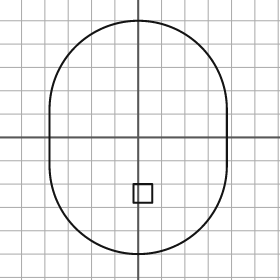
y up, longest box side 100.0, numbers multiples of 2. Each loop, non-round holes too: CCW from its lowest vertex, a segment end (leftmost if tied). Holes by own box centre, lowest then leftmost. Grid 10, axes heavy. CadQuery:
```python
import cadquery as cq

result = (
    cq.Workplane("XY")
    .moveTo(-38.0, -12.0)
    .threePointArc((0.0, -50.0), (38.0, -12.0))
    .lineTo(38.0, 12.0)
    .threePointArc((0.0, 50.0), (-38.0, 12.0))
    .close()
    .moveTo(-2.0, -28.0)
    .lineTo(6.0, -28.0)
    .lineTo(6.0, -20.0)
    .lineTo(-2.0, -20.0)
    .close()
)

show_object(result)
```